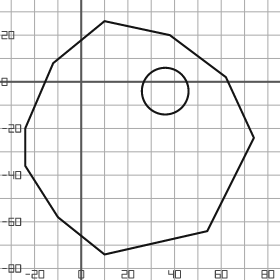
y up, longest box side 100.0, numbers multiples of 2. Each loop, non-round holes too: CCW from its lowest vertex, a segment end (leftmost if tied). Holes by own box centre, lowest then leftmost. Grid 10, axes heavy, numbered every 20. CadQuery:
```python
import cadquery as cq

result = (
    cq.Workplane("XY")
    .moveTo(10.0, -74.0)
    .lineTo(54.0, -64.0)
    .lineTo(74.0, -24.0)
    .lineTo(62.0, 2.0)
    .lineTo(38.0, 20.0)
    .lineTo(10.0, 26.0)
    .lineTo(-12.0, 8.0)
    .lineTo(-24.0, -20.0)
    .lineTo(-24.0, -36.0)
    .lineTo(-10.0, -58.0)
    .close()
    .moveTo(36.0, -4.0)
    .circle(10.0)
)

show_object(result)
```